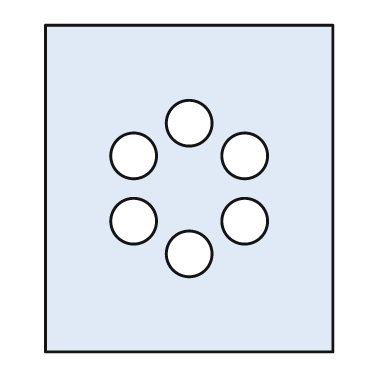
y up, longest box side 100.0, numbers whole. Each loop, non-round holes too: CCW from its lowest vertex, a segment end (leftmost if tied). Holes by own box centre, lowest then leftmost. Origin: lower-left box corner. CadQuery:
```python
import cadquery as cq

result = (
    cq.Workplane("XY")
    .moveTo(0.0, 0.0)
    .lineTo(88.0, 0.0)
    .lineTo(88.0, 100.0)
    .lineTo(0.0, 100.0)
    .close()
    .moveTo(44.0, 30.0)
    .circle(7.0)
    .moveTo(27.0, 40.0)
    .circle(7.0)
    .moveTo(61.0, 40.0)
    .circle(7.0)
    .moveTo(27.0, 60.0)
    .circle(7.0)
    .moveTo(61.0, 60.0)
    .circle(7.0)
    .moveTo(44.0, 70.0)
    .circle(7.0)
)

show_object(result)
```